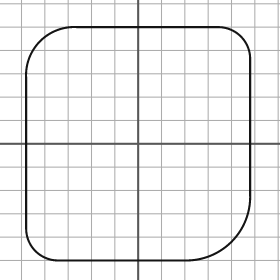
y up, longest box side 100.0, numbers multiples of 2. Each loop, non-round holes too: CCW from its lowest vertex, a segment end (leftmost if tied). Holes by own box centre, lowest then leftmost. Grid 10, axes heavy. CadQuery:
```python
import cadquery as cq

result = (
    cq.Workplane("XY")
    .moveTo(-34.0, -50.0)
    .lineTo(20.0, -50.0)
    .threePointArc((40.0, -42.0), (48.0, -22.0))
    .lineTo(48.0, 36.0)
    .threePointArc((44.0, 46.0), (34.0, 50.0))
    .lineTo(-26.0, 50.0)
    .threePointArc((-42.0, 44.0), (-48.0, 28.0))
    .lineTo(-48.0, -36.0)
    .threePointArc((-44.0, -46.0), (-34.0, -50.0))
    .close()
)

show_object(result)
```